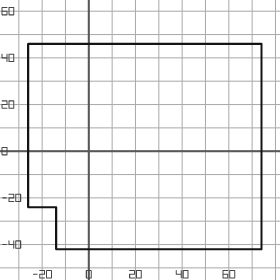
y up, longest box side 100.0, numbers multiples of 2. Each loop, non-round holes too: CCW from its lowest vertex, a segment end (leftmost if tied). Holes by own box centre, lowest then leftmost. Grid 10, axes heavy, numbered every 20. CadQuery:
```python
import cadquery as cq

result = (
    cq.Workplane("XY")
    .moveTo(-14.0, -42.0)
    .lineTo(74.0, -42.0)
    .lineTo(74.0, 46.0)
    .lineTo(-26.0, 46.0)
    .lineTo(-26.0, -24.0)
    .lineTo(-14.0, -24.0)
    .close()
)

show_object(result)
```